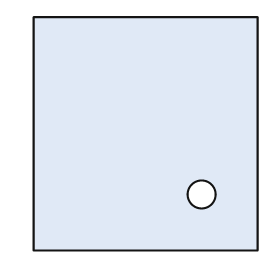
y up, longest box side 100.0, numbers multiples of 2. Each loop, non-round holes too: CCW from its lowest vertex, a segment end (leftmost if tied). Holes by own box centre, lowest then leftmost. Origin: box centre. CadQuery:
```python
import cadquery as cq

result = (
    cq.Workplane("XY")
    .moveTo(-48.0, -50.0)
    .lineTo(48.0, -50.0)
    .lineTo(48.0, 50.0)
    .lineTo(-48.0, 50.0)
    .close()
    .moveTo(24.0, -26.0)
    .circle(6.0)
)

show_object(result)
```